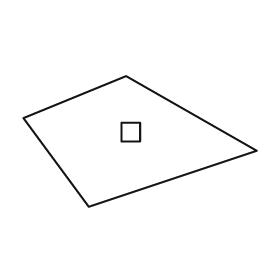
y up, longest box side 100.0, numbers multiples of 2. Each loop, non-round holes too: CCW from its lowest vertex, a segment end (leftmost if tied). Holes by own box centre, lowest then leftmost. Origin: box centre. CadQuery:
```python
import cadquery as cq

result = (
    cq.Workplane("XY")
    .moveTo(-22.0, -28.0)
    .lineTo(50.0, -4.0)
    .lineTo(-6.0, 28.0)
    .lineTo(-50.0, 10.0)
    .close()
    .moveTo(-8.0, 0.0)
    .lineTo(0.0, 0.0)
    .lineTo(0.0, 8.0)
    .lineTo(-8.0, 8.0)
    .close()
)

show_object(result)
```